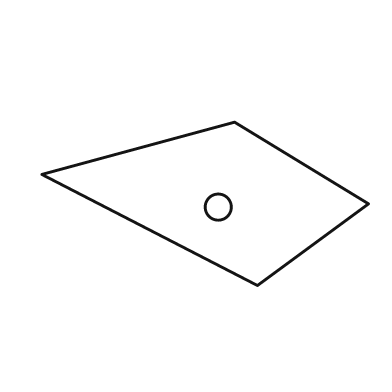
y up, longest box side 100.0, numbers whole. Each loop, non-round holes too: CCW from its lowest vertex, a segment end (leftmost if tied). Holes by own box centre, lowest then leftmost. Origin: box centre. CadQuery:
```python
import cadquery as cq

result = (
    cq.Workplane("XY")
    .moveTo(16.0, -25.0)
    .lineTo(50.0, 0.0)
    .lineTo(9.0, 25.0)
    .lineTo(-50.0, 9.0)
    .close()
    .moveTo(4.0, -1.0)
    .circle(4.0)
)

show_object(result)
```